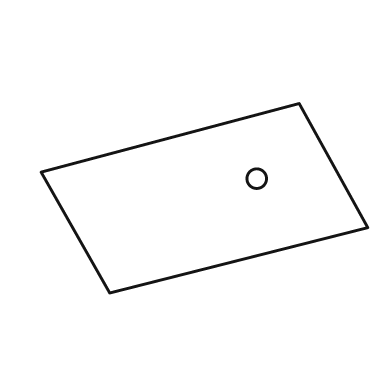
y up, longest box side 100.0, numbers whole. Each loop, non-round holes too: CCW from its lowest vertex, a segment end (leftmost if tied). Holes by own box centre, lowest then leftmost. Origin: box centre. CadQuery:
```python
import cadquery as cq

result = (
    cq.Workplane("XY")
    .moveTo(-29.0, -29.0)
    .lineTo(50.0, -9.0)
    .lineTo(29.0, 29.0)
    .lineTo(-50.0, 8.0)
    .close()
    .moveTo(16.0, 6.0)
    .circle(3.0)
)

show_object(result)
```